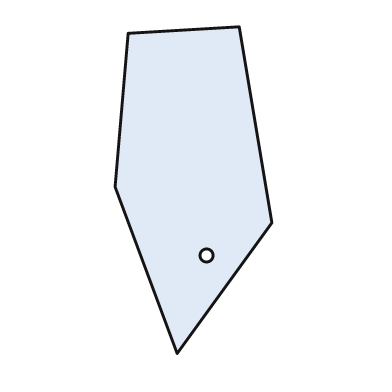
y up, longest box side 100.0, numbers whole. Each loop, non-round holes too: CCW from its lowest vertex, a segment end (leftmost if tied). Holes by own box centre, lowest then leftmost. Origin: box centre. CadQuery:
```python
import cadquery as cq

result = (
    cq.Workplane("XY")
    .moveTo(-5.0, -50.0)
    .lineTo(24.0, -10.0)
    .lineTo(14.0, 50.0)
    .lineTo(-20.0, 48.0)
    .lineTo(-24.0, 1.0)
    .close()
    .moveTo(4.0, -20.0)
    .circle(2.0)
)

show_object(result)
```